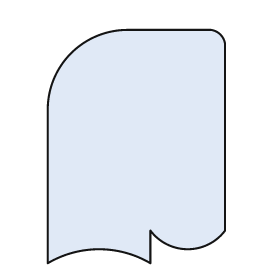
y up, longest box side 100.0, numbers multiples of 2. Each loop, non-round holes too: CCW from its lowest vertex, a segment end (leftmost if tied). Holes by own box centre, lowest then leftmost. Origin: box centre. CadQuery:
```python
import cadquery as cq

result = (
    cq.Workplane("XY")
    .moveTo(-38.0, -50.0)
    .threePointArc((-16.0, -44.0), (6.0, -50.0))
    .lineTo(6.0, -36.0)
    .threePointArc((22.0, -44.0), (38.0, -36.0))
    .lineTo(38.0, 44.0)
    .threePointArc((36.0, 48.0), (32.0, 50.0))
    .lineTo(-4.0, 50.0)
    .threePointArc((-28.0, 40.0), (-38.0, 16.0))
    .close()
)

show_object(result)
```